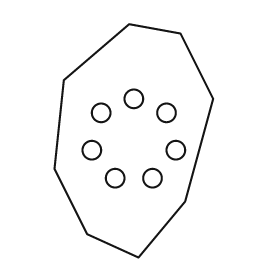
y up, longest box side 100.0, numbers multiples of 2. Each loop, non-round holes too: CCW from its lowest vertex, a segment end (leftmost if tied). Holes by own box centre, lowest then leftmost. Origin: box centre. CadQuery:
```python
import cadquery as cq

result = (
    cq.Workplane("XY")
    .moveTo(2.0, -50.0)
    .lineTo(22.0, -26.0)
    .lineTo(34.0, 18.0)
    .lineTo(20.0, 46.0)
    .lineTo(-2.0, 50.0)
    .lineTo(-30.0, 26.0)
    .lineTo(-34.0, -12.0)
    .lineTo(-20.0, -40.0)
    .close()
    .moveTo(-8.0, -16.0)
    .circle(4.0)
    .moveTo(8.0, -16.0)
    .circle(4.0)
    .moveTo(-18.0, -4.0)
    .circle(4.0)
    .moveTo(18.0, -4.0)
    .circle(4.0)
    .moveTo(-14.0, 12.0)
    .circle(4.0)
    .moveTo(14.0, 12.0)
    .circle(4.0)
    .moveTo(0.0, 18.0)
    .circle(4.0)
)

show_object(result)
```